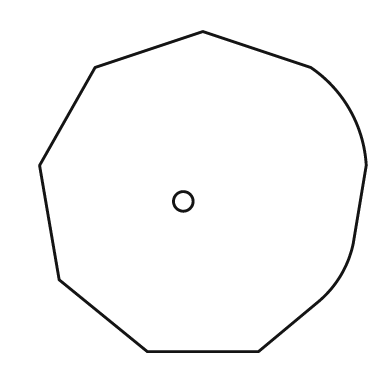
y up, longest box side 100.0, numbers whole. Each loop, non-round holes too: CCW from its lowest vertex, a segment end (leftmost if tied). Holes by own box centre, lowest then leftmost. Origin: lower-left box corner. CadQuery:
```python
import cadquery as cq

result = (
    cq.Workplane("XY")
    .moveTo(33.0, 0.0)
    .lineTo(67.0, 0.0)
    .lineTo(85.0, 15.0)
    .threePointArc((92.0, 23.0), (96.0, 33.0))
    .lineTo(100.0, 57.0)
    .threePointArc((95.0, 74.0), (83.0, 87.0))
    .lineTo(50.0, 98.0)
    .lineTo(17.0, 87.0)
    .lineTo(0.0, 57.0)
    .lineTo(6.0, 22.0)
    .close()
    .moveTo(44.0, 46.0)
    .circle(3.0)
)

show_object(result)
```